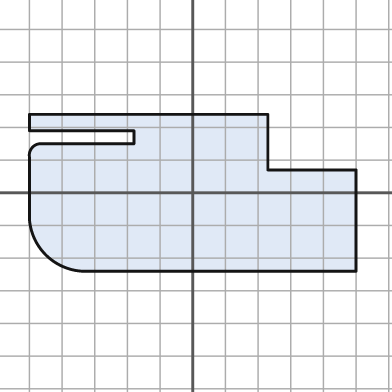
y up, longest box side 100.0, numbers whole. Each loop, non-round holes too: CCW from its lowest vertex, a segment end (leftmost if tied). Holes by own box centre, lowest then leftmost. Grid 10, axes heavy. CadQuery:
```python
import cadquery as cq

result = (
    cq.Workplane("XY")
    .moveTo(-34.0, -24.0)
    .lineTo(50.0, -24.0)
    .lineTo(50.0, 7.0)
    .lineTo(23.0, 7.0)
    .lineTo(23.0, 24.0)
    .lineTo(-50.0, 24.0)
    .lineTo(-50.0, 19.0)
    .lineTo(-18.0, 19.0)
    .lineTo(-18.0, 15.0)
    .lineTo(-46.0, 15.0)
    .threePointArc((-49.0, 14.0), (-50.0, 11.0))
    .lineTo(-50.0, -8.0)
    .threePointArc((-45.0, -19.0), (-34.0, -24.0))
    .close()
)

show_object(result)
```